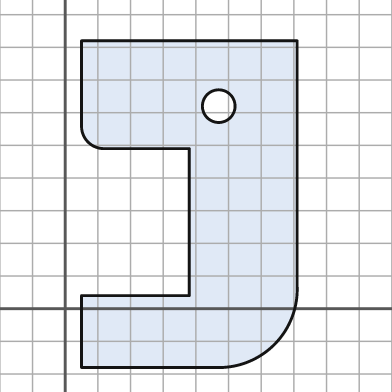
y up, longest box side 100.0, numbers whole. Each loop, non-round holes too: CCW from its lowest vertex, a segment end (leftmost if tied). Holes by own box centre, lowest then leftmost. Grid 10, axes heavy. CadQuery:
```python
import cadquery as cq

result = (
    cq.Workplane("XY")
    .moveTo(5.0, -18.0)
    .lineTo(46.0, -18.0)
    .threePointArc((64.0, -11.0), (71.0, 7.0))
    .lineTo(71.0, 82.0)
    .lineTo(5.0, 82.0)
    .lineTo(5.0, 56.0)
    .threePointArc((7.0, 51.0), (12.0, 49.0))
    .lineTo(38.0, 49.0)
    .lineTo(38.0, 4.0)
    .lineTo(5.0, 4.0)
    .close()
    .moveTo(47.0, 62.0)
    .circle(5.0)
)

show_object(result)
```